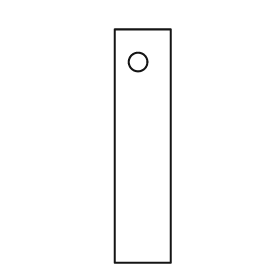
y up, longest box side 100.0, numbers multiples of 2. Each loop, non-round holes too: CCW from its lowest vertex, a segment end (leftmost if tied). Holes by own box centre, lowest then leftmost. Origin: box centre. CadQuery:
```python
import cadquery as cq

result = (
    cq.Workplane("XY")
    .moveTo(-12.0, -50.0)
    .lineTo(12.0, -50.0)
    .lineTo(12.0, 50.0)
    .lineTo(-12.0, 50.0)
    .close()
    .moveTo(-2.0, 36.0)
    .circle(4.0)
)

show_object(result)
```